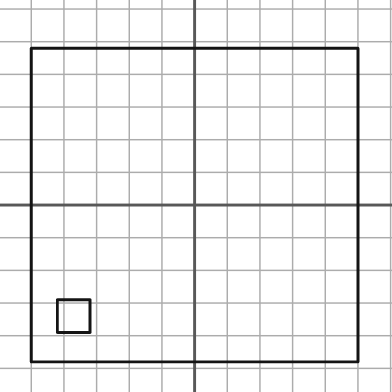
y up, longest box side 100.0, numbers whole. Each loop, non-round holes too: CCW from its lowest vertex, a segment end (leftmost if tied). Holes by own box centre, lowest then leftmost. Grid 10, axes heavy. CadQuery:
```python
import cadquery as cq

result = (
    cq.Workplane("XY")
    .moveTo(-50.0, -48.0)
    .lineTo(50.0, -48.0)
    .lineTo(50.0, 48.0)
    .lineTo(-50.0, 48.0)
    .close()
    .moveTo(-42.0, -39.0)
    .lineTo(-32.0, -39.0)
    .lineTo(-32.0, -29.0)
    .lineTo(-42.0, -29.0)
    .close()
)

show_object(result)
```